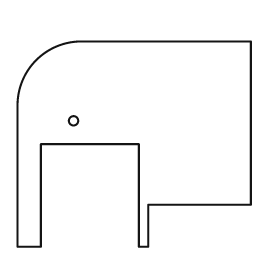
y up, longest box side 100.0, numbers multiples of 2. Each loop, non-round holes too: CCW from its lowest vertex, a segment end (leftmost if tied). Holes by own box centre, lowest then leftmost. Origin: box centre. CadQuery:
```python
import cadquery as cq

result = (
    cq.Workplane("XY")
    .moveTo(-50.0, -44.0)
    .lineTo(-40.0, -44.0)
    .lineTo(-40.0, 0.0)
    .lineTo(2.0, 0.0)
    .lineTo(2.0, -44.0)
    .lineTo(6.0, -44.0)
    .lineTo(6.0, -26.0)
    .lineTo(50.0, -26.0)
    .lineTo(50.0, 44.0)
    .lineTo(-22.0, 44.0)
    .threePointArc((-42.0, 36.0), (-50.0, 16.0))
    .close()
    .moveTo(-26.0, 10.0)
    .circle(2.0)
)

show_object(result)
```